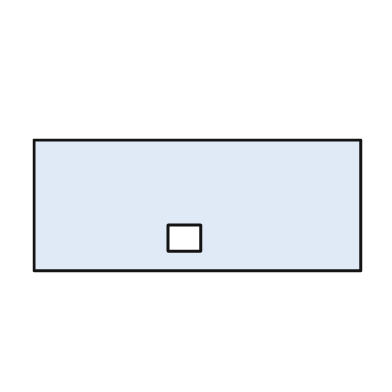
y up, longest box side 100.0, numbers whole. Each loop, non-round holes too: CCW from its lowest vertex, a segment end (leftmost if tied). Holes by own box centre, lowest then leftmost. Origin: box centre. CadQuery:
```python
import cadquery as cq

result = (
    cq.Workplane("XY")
    .moveTo(-50.0, -20.0)
    .lineTo(50.0, -20.0)
    .lineTo(50.0, 20.0)
    .lineTo(-50.0, 20.0)
    .close()
    .moveTo(-9.0, -14.0)
    .lineTo(1.0, -14.0)
    .lineTo(1.0, -6.0)
    .lineTo(-9.0, -6.0)
    .close()
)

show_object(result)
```